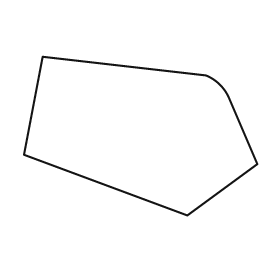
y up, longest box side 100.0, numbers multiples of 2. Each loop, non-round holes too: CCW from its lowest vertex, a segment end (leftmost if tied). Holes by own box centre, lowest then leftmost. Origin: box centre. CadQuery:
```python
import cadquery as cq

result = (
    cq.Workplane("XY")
    .moveTo(20.0, -34.0)
    .lineTo(50.0, -12.0)
    .lineTo(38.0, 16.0)
    .threePointArc((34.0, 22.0), (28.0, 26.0))
    .lineTo(-42.0, 34.0)
    .lineTo(-50.0, -8.0)
    .close()
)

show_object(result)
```